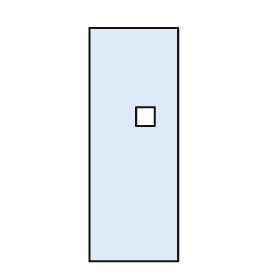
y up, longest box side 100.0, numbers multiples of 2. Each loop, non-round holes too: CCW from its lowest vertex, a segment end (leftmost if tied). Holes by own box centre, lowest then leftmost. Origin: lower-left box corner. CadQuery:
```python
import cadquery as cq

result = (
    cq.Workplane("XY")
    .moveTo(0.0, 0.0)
    .lineTo(38.0, 0.0)
    .lineTo(38.0, 100.0)
    .lineTo(0.0, 100.0)
    .close()
    .moveTo(20.0, 58.0)
    .lineTo(28.0, 58.0)
    .lineTo(28.0, 66.0)
    .lineTo(20.0, 66.0)
    .close()
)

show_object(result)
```